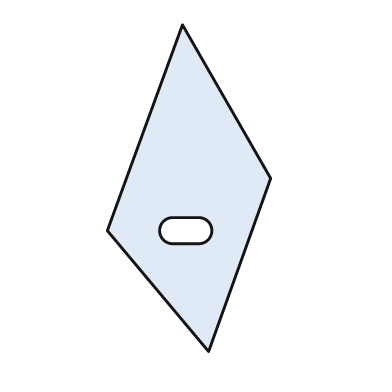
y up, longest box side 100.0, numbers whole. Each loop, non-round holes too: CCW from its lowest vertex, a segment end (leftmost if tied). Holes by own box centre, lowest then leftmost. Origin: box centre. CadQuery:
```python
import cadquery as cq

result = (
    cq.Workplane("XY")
    .moveTo(6.0, -50.0)
    .lineTo(25.0, 3.0)
    .lineTo(-2.0, 50.0)
    .lineTo(-25.0, -13.0)
    .close()
    .moveTo(-5.0, -17.0)
    .lineTo(3.0, -17.0)
    .threePointArc((7.0, -13.0), (3.0, -9.0))
    .lineTo(-5.0, -9.0)
    .threePointArc((-9.0, -13.0), (-5.0, -17.0))
    .close()
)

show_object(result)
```